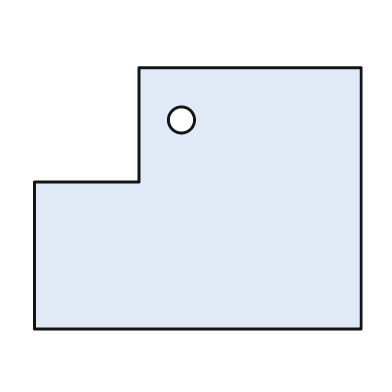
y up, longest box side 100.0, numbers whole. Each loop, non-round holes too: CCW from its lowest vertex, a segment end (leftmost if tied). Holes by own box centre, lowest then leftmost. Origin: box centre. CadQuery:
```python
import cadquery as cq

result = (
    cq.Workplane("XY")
    .moveTo(-50.0, -40.0)
    .lineTo(50.0, -40.0)
    .lineTo(50.0, 40.0)
    .lineTo(-18.0, 40.0)
    .lineTo(-18.0, 5.0)
    .lineTo(-50.0, 5.0)
    .close()
    .moveTo(-5.0, 24.0)
    .circle(4.0)
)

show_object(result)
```